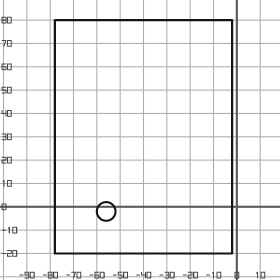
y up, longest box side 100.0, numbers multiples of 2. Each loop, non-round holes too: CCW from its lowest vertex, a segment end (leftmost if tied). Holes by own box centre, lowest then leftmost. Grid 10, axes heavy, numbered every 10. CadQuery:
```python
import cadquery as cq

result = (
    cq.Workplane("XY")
    .moveTo(-78.0, -20.0)
    .lineTo(-2.0, -20.0)
    .lineTo(-2.0, 80.0)
    .lineTo(-78.0, 80.0)
    .close()
    .moveTo(-56.0, -2.0)
    .circle(4.0)
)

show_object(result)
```